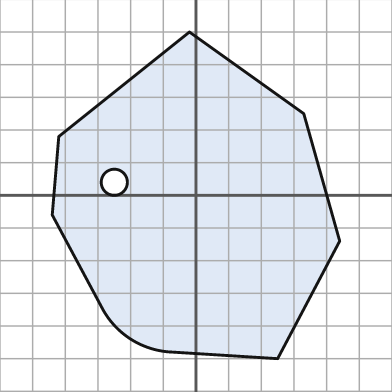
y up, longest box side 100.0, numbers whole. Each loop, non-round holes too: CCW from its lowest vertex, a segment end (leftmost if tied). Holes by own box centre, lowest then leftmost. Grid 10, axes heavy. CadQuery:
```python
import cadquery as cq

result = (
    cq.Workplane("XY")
    .moveTo(25.0, -50.0)
    .lineTo(44.0, -14.0)
    .lineTo(33.0, 25.0)
    .lineTo(-2.0, 50.0)
    .lineTo(-42.0, 18.0)
    .lineTo(-44.0, -6.0)
    .lineTo(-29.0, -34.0)
    .threePointArc((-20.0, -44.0), (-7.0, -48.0))
    .close()
    .moveTo(-25.0, 4.0)
    .circle(4.0)
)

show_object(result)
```